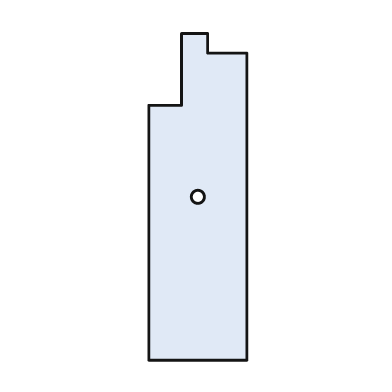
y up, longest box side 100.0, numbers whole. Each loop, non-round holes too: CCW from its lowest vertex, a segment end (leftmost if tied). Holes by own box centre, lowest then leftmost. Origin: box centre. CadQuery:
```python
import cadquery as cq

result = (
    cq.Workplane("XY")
    .moveTo(-15.0, -50.0)
    .lineTo(15.0, -50.0)
    .lineTo(15.0, 44.0)
    .lineTo(3.0, 44.0)
    .lineTo(3.0, 50.0)
    .lineTo(-5.0, 50.0)
    .lineTo(-5.0, 28.0)
    .lineTo(-15.0, 28.0)
    .close()
    .moveTo(0.0, 0.0)
    .circle(2.0)
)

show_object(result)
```